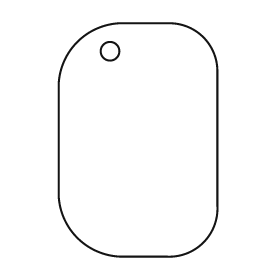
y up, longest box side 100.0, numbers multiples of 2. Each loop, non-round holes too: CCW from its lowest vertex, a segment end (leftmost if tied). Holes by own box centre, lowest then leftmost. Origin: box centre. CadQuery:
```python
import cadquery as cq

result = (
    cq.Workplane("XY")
    .moveTo(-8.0, -50.0)
    .lineTo(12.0, -50.0)
    .threePointArc((28.0, -44.0), (34.0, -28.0))
    .lineTo(34.0, 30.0)
    .threePointArc((28.0, 44.0), (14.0, 50.0))
    .lineTo(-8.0, 50.0)
    .threePointArc((-26.0, 42.0), (-34.0, 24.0))
    .lineTo(-34.0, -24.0)
    .threePointArc((-26.0, -42.0), (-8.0, -50.0))
    .close()
    .moveTo(-12.0, 38.0)
    .circle(4.0)
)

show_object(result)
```